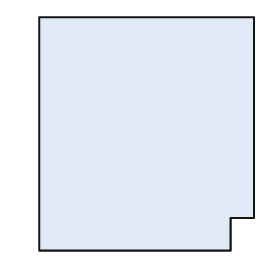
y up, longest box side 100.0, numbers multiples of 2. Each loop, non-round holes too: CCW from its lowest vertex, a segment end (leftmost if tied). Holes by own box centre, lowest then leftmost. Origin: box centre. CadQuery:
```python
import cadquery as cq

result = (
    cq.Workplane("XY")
    .moveTo(-46.0, -50.0)
    .lineTo(36.0, -50.0)
    .lineTo(36.0, -36.0)
    .lineTo(46.0, -36.0)
    .lineTo(46.0, 50.0)
    .lineTo(-46.0, 50.0)
    .close()
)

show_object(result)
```